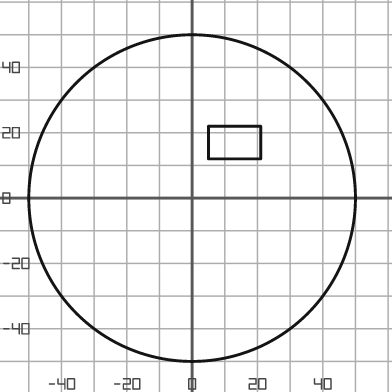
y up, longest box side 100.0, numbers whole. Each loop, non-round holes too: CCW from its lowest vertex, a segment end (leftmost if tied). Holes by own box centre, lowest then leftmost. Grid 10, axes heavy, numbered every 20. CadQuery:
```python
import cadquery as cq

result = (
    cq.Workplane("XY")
    .moveTo(0.0, 0.0)
    .circle(50.0)
    .moveTo(5.0, 12.0)
    .lineTo(21.0, 12.0)
    .lineTo(21.0, 22.0)
    .lineTo(5.0, 22.0)
    .close()
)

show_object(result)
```